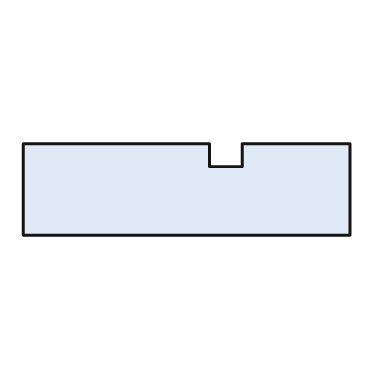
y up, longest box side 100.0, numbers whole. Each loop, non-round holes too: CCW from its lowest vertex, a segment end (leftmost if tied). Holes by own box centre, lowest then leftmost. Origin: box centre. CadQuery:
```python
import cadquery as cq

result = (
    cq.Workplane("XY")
    .moveTo(-50.0, -14.0)
    .lineTo(50.0, -14.0)
    .lineTo(50.0, 14.0)
    .lineTo(17.0, 14.0)
    .lineTo(17.0, 7.0)
    .lineTo(7.0, 7.0)
    .lineTo(7.0, 14.0)
    .lineTo(-50.0, 14.0)
    .close()
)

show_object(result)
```